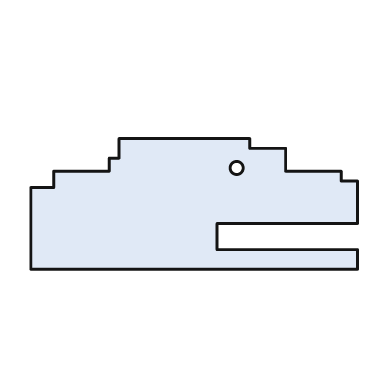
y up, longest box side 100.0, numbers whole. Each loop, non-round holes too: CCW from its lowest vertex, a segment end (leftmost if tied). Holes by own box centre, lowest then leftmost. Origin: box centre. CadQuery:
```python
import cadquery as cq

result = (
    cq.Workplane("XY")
    .moveTo(-50.0, -20.0)
    .lineTo(50.0, -20.0)
    .lineTo(50.0, -14.0)
    .lineTo(7.0, -14.0)
    .lineTo(7.0, -6.0)
    .lineTo(50.0, -6.0)
    .lineTo(50.0, 7.0)
    .lineTo(45.0, 7.0)
    .lineTo(45.0, 10.0)
    .lineTo(28.0, 10.0)
    .lineTo(28.0, 17.0)
    .lineTo(17.0, 17.0)
    .lineTo(17.0, 20.0)
    .lineTo(-23.0, 20.0)
    .lineTo(-23.0, 14.0)
    .lineTo(-26.0, 14.0)
    .lineTo(-26.0, 10.0)
    .lineTo(-43.0, 10.0)
    .lineTo(-43.0, 5.0)
    .lineTo(-50.0, 5.0)
    .close()
    .moveTo(13.0, 11.0)
    .circle(2.0)
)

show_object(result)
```